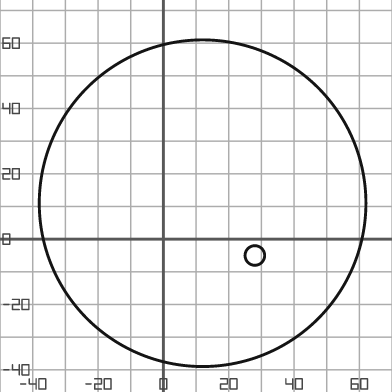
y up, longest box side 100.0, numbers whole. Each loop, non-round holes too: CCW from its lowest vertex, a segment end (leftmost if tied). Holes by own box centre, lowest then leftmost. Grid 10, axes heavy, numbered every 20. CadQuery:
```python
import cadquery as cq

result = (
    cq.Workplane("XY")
    .moveTo(12.0, 11.0)
    .circle(50.0)
    .moveTo(28.0, -5.0)
    .circle(3.0)
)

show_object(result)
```